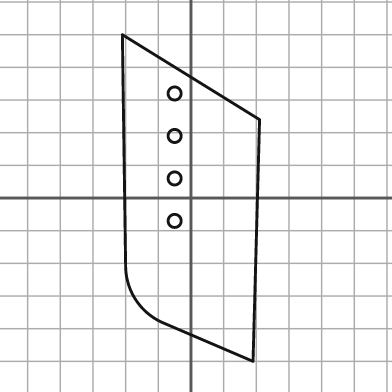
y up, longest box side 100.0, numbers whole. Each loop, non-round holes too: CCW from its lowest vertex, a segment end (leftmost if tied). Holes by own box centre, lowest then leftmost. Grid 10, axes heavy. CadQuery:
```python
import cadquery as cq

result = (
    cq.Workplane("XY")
    .moveTo(19.0, -50.0)
    .lineTo(21.0, 24.0)
    .lineTo(-21.0, 50.0)
    .lineTo(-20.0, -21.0)
    .threePointArc((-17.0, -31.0), (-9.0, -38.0))
    .close()
    .moveTo(-5.0, -7.0)
    .circle(2.0)
    .moveTo(-5.0, 6.0)
    .circle(2.0)
    .moveTo(-5.0, 19.0)
    .circle(2.0)
    .moveTo(-5.0, 32.0)
    .circle(2.0)
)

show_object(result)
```